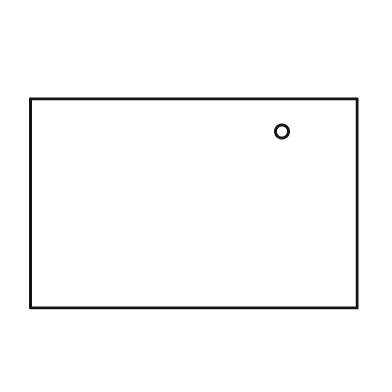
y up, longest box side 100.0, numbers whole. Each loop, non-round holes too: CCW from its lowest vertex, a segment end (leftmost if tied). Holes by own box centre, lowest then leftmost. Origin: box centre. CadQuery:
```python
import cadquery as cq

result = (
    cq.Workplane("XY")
    .moveTo(-50.0, -32.0)
    .lineTo(50.0, -32.0)
    .lineTo(50.0, 32.0)
    .lineTo(-50.0, 32.0)
    .close()
    .moveTo(27.0, 22.0)
    .circle(2.0)
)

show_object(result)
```